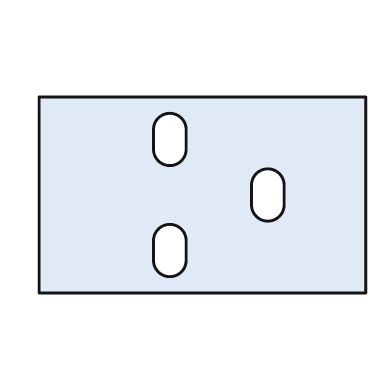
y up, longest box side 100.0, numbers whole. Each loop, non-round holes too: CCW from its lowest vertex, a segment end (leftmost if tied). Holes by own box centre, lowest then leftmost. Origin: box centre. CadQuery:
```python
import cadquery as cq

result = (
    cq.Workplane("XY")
    .moveTo(-50.0, -30.0)
    .lineTo(50.0, -30.0)
    .lineTo(50.0, 30.0)
    .lineTo(-50.0, 30.0)
    .close()
    .moveTo(-15.0, -20.0)
    .threePointArc((-10.0, -25.0), (-5.0, -20.0))
    .lineTo(-5.0, -14.0)
    .threePointArc((-10.0, -9.0), (-15.0, -14.0))
    .close()
    .moveTo(15.0, -3.0)
    .threePointArc((20.0, -8.0), (25.0, -3.0))
    .lineTo(25.0, 3.0)
    .threePointArc((20.0, 8.0), (15.0, 3.0))
    .close()
    .moveTo(-15.0, 14.0)
    .threePointArc((-10.0, 9.0), (-5.0, 14.0))
    .lineTo(-5.0, 20.0)
    .threePointArc((-10.0, 25.0), (-15.0, 20.0))
    .close()
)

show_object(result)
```